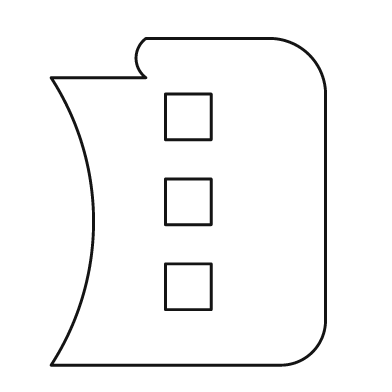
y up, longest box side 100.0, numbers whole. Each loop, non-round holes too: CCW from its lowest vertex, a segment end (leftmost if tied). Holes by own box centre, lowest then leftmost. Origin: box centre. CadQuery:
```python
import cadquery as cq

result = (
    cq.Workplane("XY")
    .moveTo(-42.0, -50.0)
    .lineTo(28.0, -50.0)
    .threePointArc((38.0, -46.0), (42.0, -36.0))
    .lineTo(42.0, 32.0)
    .threePointArc((37.0, 45.0), (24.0, 50.0))
    .lineTo(-13.0, 50.0)
    .threePointArc((-16.0, 44.0), (-13.0, 38.0))
    .lineTo(-42.0, 38.0)
    .threePointArc((-29.0, -6.0), (-42.0, -50.0))
    .close()
    .moveTo(-7.0, -33.0)
    .lineTo(7.0, -33.0)
    .lineTo(7.0, -19.0)
    .lineTo(-7.0, -19.0)
    .close()
    .moveTo(-7.0, -7.0)
    .lineTo(7.0, -7.0)
    .lineTo(7.0, 7.0)
    .lineTo(-7.0, 7.0)
    .close()
    .moveTo(-7.0, 19.0)
    .lineTo(7.0, 19.0)
    .lineTo(7.0, 33.0)
    .lineTo(-7.0, 33.0)
    .close()
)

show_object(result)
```